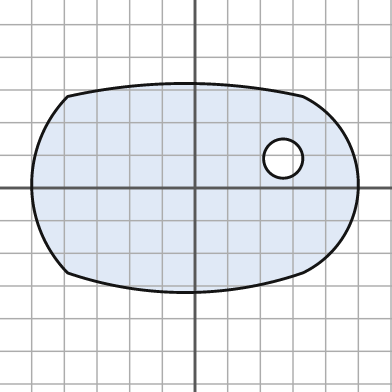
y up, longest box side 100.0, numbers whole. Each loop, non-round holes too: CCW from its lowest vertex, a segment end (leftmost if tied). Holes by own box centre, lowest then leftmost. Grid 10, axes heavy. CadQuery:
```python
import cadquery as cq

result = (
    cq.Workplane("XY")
    .moveTo(-39.0, -26.0)
    .threePointArc((-3.0, -32.0), (33.0, -26.0))
    .threePointArc((50.0, 1.0), (33.0, 28.0))
    .threePointArc((-3.0, 32.0), (-39.0, 28.0))
    .threePointArc((-50.0, 1.0), (-39.0, -26.0))
    .close()
    .moveTo(27.0, 9.0)
    .circle(6.0)
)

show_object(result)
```